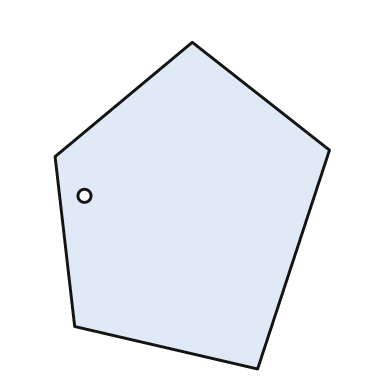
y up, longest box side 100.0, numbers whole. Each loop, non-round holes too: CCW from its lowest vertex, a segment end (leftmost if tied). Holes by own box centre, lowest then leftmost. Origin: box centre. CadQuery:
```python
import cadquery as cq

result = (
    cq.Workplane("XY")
    .moveTo(20.0, -50.0)
    .lineTo(42.0, 17.0)
    .lineTo(0.0, 50.0)
    .lineTo(-42.0, 15.0)
    .lineTo(-36.0, -37.0)
    .close()
    .moveTo(-33.0, 3.0)
    .circle(2.0)
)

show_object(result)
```